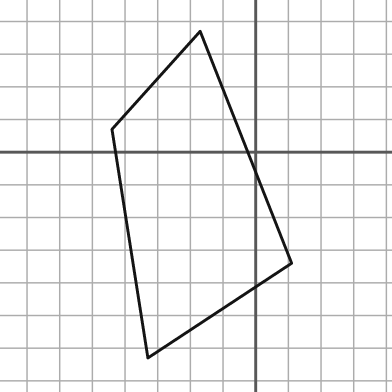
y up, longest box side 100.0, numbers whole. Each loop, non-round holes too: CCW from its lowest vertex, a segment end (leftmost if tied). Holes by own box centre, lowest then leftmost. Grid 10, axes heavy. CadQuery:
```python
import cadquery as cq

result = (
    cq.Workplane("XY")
    .moveTo(-33.0, -63.0)
    .lineTo(11.0, -34.0)
    .lineTo(-17.0, 37.0)
    .lineTo(-44.0, 7.0)
    .close()
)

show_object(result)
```